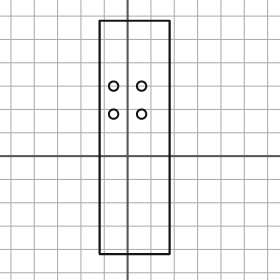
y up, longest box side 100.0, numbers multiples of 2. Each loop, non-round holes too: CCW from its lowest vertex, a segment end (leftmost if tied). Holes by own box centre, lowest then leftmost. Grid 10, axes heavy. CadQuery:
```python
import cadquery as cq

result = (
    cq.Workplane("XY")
    .moveTo(-12.0, -42.0)
    .lineTo(18.0, -42.0)
    .lineTo(18.0, 58.0)
    .lineTo(-12.0, 58.0)
    .close()
    .moveTo(-6.0, 18.0)
    .circle(2.0)
    .moveTo(6.0, 18.0)
    .circle(2.0)
    .moveTo(-6.0, 30.0)
    .circle(2.0)
    .moveTo(6.0, 30.0)
    .circle(2.0)
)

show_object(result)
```